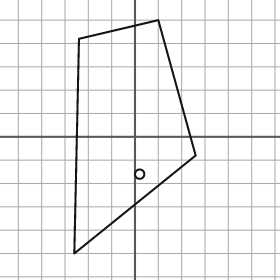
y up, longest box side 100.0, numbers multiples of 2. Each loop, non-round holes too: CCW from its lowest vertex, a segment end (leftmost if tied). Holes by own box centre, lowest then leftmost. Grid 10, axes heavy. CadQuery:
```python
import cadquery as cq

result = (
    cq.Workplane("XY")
    .moveTo(-26.0, -50.0)
    .lineTo(26.0, -8.0)
    .lineTo(10.0, 50.0)
    .lineTo(-24.0, 42.0)
    .close()
    .moveTo(2.0, -16.0)
    .circle(2.0)
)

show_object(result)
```